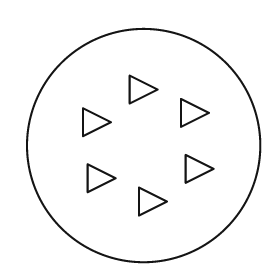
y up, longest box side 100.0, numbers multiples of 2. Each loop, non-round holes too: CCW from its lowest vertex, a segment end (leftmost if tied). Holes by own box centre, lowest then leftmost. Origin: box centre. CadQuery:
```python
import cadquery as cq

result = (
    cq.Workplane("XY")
    .moveTo(0.0, 0.0)
    .circle(50.0)
    .moveTo(-2.0, -30.0)
    .lineTo(10.0, -24.0)
    .lineTo(-2.0, -18.0)
    .close()
    .moveTo(-24.0, -20.0)
    .lineTo(-12.0, -14.0)
    .lineTo(-24.0, -8.0)
    .close()
    .moveTo(18.0, -16.0)
    .lineTo(30.0, -10.0)
    .lineTo(18.0, -4.0)
    .close()
    .moveTo(-26.0, 4.0)
    .lineTo(-14.0, 10.0)
    .lineTo(-26.0, 16.0)
    .close()
    .moveTo(16.0, 8.0)
    .lineTo(28.0, 14.0)
    .lineTo(16.0, 20.0)
    .close()
    .moveTo(-6.0, 18.0)
    .lineTo(6.0, 24.0)
    .lineTo(-6.0, 30.0)
    .close()
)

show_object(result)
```